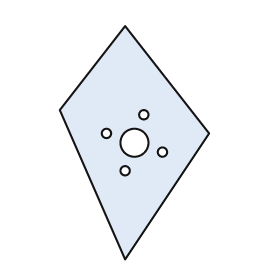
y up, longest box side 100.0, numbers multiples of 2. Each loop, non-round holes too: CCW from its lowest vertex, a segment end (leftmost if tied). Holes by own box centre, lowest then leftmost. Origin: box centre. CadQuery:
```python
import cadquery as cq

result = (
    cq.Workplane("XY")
    .moveTo(-4.0, -50.0)
    .lineTo(32.0, 4.0)
    .lineTo(-4.0, 50.0)
    .lineTo(-32.0, 14.0)
    .close()
    .moveTo(-4.0, -12.0)
    .circle(2.0)
    .moveTo(12.0, -4.0)
    .circle(2.0)
    .moveTo(0.0, 0.0)
    .circle(6.0)
    .moveTo(-12.0, 4.0)
    .circle(2.0)
    .moveTo(4.0, 12.0)
    .circle(2.0)
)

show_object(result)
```